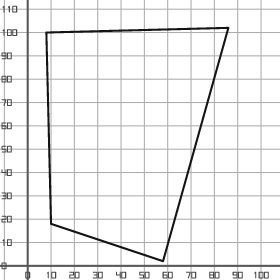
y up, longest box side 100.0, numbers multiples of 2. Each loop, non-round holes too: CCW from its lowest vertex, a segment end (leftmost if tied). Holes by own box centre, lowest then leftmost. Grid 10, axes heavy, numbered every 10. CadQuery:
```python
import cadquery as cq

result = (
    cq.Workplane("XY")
    .moveTo(58.0, 2.0)
    .lineTo(86.0, 102.0)
    .lineTo(8.0, 100.0)
    .lineTo(10.0, 18.0)
    .close()
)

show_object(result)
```